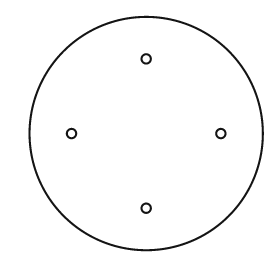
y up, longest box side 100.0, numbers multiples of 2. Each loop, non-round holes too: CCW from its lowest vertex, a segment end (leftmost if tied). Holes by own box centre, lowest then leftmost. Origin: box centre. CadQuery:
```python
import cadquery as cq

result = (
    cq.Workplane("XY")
    .moveTo(0.0, 0.0)
    .circle(50.0)
    .moveTo(0.0, -32.0)
    .circle(2.0)
    .moveTo(-32.0, 0.0)
    .circle(2.0)
    .moveTo(32.0, 0.0)
    .circle(2.0)
    .moveTo(0.0, 32.0)
    .circle(2.0)
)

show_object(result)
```